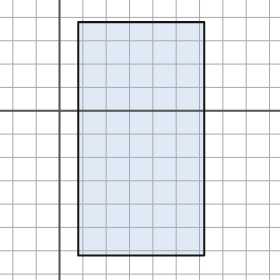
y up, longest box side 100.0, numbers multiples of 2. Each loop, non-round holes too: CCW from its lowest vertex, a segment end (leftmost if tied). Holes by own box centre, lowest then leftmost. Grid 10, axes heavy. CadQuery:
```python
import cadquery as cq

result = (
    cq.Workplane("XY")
    .moveTo(8.0, -62.0)
    .lineTo(62.0, -62.0)
    .lineTo(62.0, 38.0)
    .lineTo(8.0, 38.0)
    .close()
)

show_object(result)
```